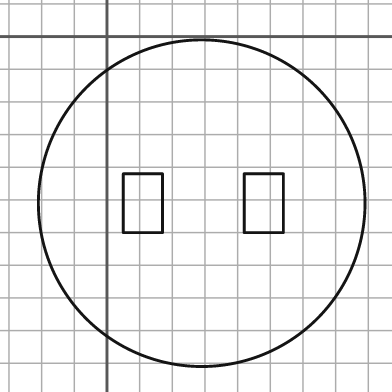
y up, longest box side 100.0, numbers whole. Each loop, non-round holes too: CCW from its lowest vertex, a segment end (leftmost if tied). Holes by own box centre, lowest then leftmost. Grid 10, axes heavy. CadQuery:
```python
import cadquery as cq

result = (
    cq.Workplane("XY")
    .moveTo(29.0, -51.0)
    .circle(50.0)
    .moveTo(5.0, -60.0)
    .lineTo(17.0, -60.0)
    .lineTo(17.0, -42.0)
    .lineTo(5.0, -42.0)
    .close()
    .moveTo(42.0, -60.0)
    .lineTo(54.0, -60.0)
    .lineTo(54.0, -42.0)
    .lineTo(42.0, -42.0)
    .close()
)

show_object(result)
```